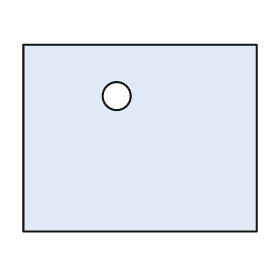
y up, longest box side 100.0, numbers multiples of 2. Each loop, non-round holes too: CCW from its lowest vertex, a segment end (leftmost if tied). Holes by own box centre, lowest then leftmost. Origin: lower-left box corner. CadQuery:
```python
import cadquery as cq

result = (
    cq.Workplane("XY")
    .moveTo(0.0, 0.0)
    .lineTo(100.0, 0.0)
    .lineTo(100.0, 80.0)
    .lineTo(0.0, 80.0)
    .close()
    .moveTo(40.0, 58.0)
    .circle(6.0)
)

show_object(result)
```